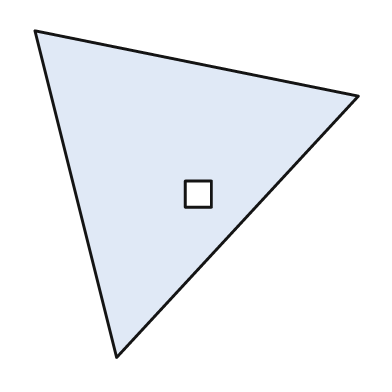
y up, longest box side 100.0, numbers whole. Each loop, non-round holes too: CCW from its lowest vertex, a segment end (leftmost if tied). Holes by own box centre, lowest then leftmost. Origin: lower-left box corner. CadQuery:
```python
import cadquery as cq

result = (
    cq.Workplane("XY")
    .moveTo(25.0, 0.0)
    .lineTo(99.0, 80.0)
    .lineTo(0.0, 100.0)
    .close()
    .moveTo(46.0, 46.0)
    .lineTo(54.0, 46.0)
    .lineTo(54.0, 54.0)
    .lineTo(46.0, 54.0)
    .close()
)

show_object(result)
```